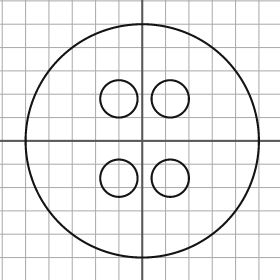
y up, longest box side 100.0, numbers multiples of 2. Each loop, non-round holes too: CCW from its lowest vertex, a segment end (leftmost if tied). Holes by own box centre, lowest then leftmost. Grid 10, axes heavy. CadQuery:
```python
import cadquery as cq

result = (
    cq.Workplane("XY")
    .moveTo(0.0, 0.0)
    .circle(50.0)
    .moveTo(-10.0, -16.0)
    .circle(8.0)
    .moveTo(12.0, -16.0)
    .circle(8.0)
    .moveTo(-10.0, 18.0)
    .circle(8.0)
    .moveTo(12.0, 18.0)
    .circle(8.0)
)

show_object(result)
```